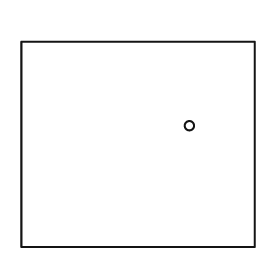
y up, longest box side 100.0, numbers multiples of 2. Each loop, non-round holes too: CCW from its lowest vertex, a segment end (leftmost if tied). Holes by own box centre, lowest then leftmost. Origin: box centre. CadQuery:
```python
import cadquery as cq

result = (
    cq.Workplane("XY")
    .moveTo(-50.0, -44.0)
    .lineTo(50.0, -44.0)
    .lineTo(50.0, 44.0)
    .lineTo(-50.0, 44.0)
    .close()
    .moveTo(22.0, 8.0)
    .circle(2.0)
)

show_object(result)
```